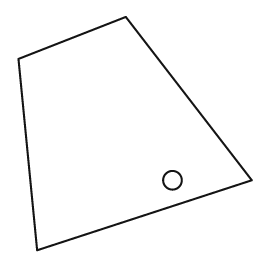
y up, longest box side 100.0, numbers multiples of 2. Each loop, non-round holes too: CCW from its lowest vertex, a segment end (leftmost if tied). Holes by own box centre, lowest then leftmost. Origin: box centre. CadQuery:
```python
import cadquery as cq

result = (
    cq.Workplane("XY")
    .moveTo(-42.0, -50.0)
    .lineTo(50.0, -20.0)
    .lineTo(-4.0, 50.0)
    .lineTo(-50.0, 32.0)
    .close()
    .moveTo(16.0, -20.0)
    .circle(4.0)
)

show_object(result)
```